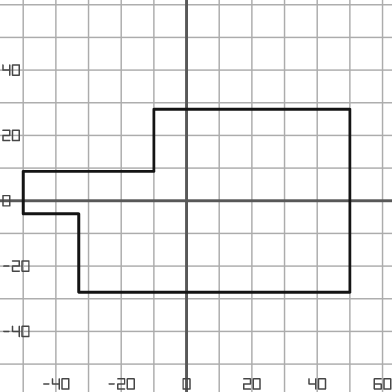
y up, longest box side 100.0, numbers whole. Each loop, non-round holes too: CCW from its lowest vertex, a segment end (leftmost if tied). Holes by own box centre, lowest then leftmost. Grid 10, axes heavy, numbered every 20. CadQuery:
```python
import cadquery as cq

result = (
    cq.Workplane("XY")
    .moveTo(-33.0, -28.0)
    .lineTo(50.0, -28.0)
    .lineTo(50.0, 28.0)
    .lineTo(-10.0, 28.0)
    .lineTo(-10.0, 9.0)
    .lineTo(-50.0, 9.0)
    .lineTo(-50.0, -4.0)
    .lineTo(-33.0, -4.0)
    .close()
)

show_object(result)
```